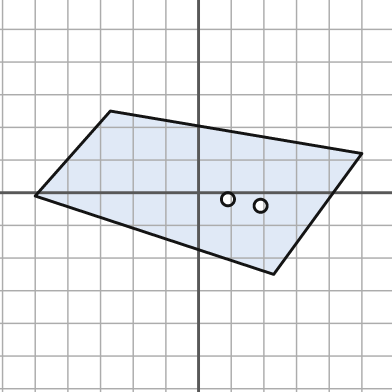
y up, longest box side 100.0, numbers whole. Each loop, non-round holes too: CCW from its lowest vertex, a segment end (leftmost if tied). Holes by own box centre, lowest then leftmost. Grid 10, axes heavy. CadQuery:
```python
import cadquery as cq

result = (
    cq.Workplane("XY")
    .moveTo(23.0, -25.0)
    .lineTo(50.0, 12.0)
    .lineTo(-27.0, 25.0)
    .lineTo(-50.0, -1.0)
    .close()
    .moveTo(19.0, -4.0)
    .circle(2.0)
    .moveTo(9.0, -2.0)
    .circle(2.0)
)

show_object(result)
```